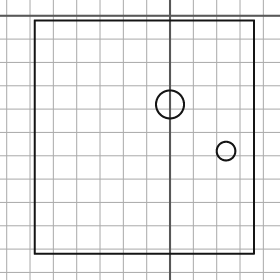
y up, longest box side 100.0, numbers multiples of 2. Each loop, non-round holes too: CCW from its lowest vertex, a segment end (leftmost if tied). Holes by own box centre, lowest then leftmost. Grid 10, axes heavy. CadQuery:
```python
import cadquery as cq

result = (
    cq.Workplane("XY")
    .moveTo(-58.0, -102.0)
    .lineTo(36.0, -102.0)
    .lineTo(36.0, -2.0)
    .lineTo(-58.0, -2.0)
    .close()
    .moveTo(24.0, -58.0)
    .circle(4.0)
    .moveTo(0.0, -38.0)
    .circle(6.0)
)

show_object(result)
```